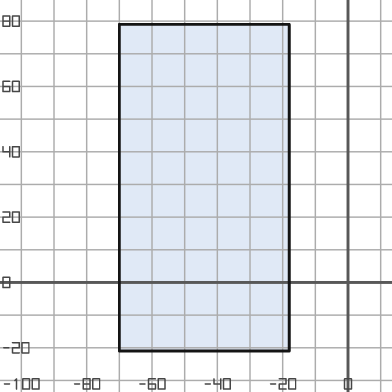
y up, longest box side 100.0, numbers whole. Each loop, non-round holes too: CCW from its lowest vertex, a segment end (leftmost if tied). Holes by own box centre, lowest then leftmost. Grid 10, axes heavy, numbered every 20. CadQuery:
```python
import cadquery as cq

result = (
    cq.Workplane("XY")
    .moveTo(-70.0, -21.0)
    .lineTo(-18.0, -21.0)
    .lineTo(-18.0, 79.0)
    .lineTo(-70.0, 79.0)
    .close()
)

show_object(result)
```